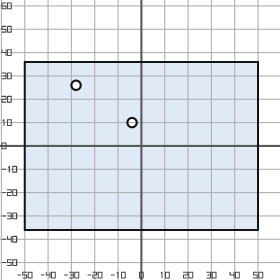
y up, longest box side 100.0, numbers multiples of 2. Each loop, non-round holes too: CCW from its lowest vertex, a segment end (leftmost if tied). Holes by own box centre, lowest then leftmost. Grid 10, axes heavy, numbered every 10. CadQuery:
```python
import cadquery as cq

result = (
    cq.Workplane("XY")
    .moveTo(-50.0, -36.0)
    .lineTo(50.0, -36.0)
    .lineTo(50.0, 36.0)
    .lineTo(-50.0, 36.0)
    .close()
    .moveTo(-4.0, 10.0)
    .circle(2.0)
    .moveTo(-28.0, 26.0)
    .circle(2.0)
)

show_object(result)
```